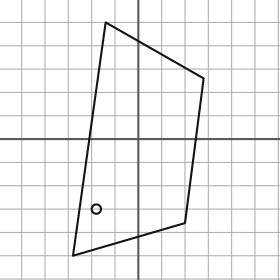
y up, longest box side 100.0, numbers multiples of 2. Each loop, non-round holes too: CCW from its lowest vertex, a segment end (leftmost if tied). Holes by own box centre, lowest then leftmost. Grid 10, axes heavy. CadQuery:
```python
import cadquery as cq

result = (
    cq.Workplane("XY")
    .moveTo(-28.0, -50.0)
    .lineTo(20.0, -36.0)
    .lineTo(28.0, 26.0)
    .lineTo(-14.0, 50.0)
    .close()
    .moveTo(-18.0, -30.0)
    .circle(2.0)
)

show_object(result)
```